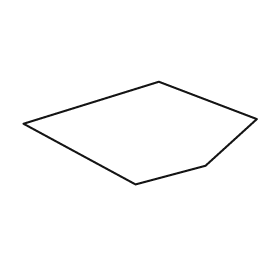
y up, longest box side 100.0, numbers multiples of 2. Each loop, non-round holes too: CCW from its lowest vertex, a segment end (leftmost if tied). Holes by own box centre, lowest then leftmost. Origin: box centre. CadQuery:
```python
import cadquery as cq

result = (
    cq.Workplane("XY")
    .moveTo(-2.0, -22.0)
    .lineTo(28.0, -14.0)
    .lineTo(50.0, 6.0)
    .lineTo(8.0, 22.0)
    .lineTo(-50.0, 4.0)
    .close()
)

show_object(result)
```